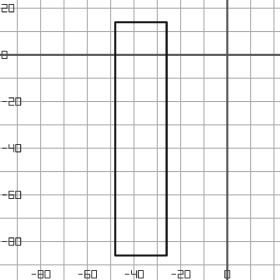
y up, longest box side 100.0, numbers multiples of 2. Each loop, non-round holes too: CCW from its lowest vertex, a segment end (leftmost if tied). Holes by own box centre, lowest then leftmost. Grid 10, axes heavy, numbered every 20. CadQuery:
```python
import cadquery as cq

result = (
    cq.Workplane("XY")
    .moveTo(-48.0, -86.0)
    .lineTo(-26.0, -86.0)
    .lineTo(-26.0, 14.0)
    .lineTo(-48.0, 14.0)
    .close()
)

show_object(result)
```